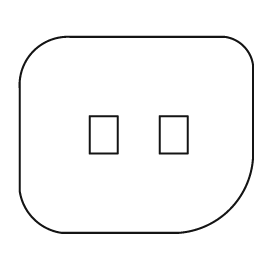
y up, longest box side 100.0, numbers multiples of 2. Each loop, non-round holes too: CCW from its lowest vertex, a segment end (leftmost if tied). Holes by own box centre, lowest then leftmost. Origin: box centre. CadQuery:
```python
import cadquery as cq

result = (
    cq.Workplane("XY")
    .moveTo(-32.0, -42.0)
    .lineTo(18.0, -42.0)
    .threePointArc((40.0, -32.0), (50.0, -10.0))
    .lineTo(50.0, 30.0)
    .threePointArc((46.0, 38.0), (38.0, 42.0))
    .lineTo(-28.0, 42.0)
    .threePointArc((-44.0, 36.0), (-50.0, 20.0))
    .lineTo(-50.0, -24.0)
    .threePointArc((-44.0, -36.0), (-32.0, -42.0))
    .close()
    .moveTo(-20.0, -8.0)
    .lineTo(-8.0, -8.0)
    .lineTo(-8.0, 8.0)
    .lineTo(-20.0, 8.0)
    .close()
    .moveTo(10.0, -8.0)
    .lineTo(22.0, -8.0)
    .lineTo(22.0, 8.0)
    .lineTo(10.0, 8.0)
    .close()
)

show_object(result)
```